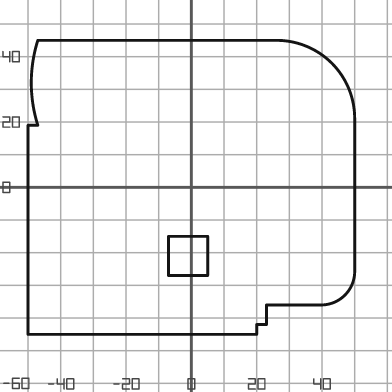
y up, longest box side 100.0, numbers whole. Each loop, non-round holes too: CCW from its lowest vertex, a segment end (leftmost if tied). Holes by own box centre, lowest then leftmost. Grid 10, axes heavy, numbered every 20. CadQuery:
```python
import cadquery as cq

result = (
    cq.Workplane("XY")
    .moveTo(-50.0, -45.0)
    .lineTo(20.0, -45.0)
    .lineTo(20.0, -42.0)
    .lineTo(23.0, -42.0)
    .lineTo(23.0, -36.0)
    .lineTo(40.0, -36.0)
    .threePointArc((47.0, -33.0), (50.0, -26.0))
    .lineTo(50.0, 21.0)
    .threePointArc((43.0, 38.0), (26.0, 45.0))
    .lineTo(-47.0, 45.0)
    .threePointArc((-49.0, 32.0), (-47.0, 19.0))
    .lineTo(-50.0, 19.0)
    .close()
    .moveTo(-7.0, -27.0)
    .lineTo(5.0, -27.0)
    .lineTo(5.0, -15.0)
    .lineTo(-7.0, -15.0)
    .close()
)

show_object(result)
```